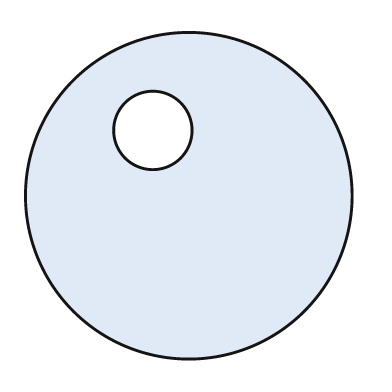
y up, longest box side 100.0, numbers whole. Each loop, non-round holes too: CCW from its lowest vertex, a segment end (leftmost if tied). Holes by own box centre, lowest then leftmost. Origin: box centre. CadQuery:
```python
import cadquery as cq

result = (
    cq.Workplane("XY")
    .moveTo(0.0, 0.0)
    .circle(50.0)
    .moveTo(-11.0, 20.0)
    .circle(12.0)
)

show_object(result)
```